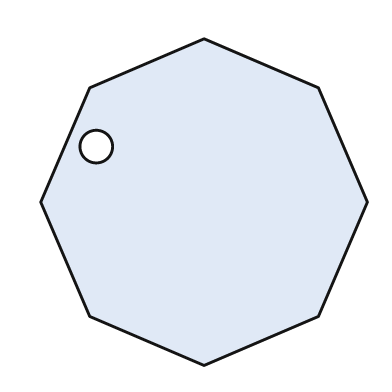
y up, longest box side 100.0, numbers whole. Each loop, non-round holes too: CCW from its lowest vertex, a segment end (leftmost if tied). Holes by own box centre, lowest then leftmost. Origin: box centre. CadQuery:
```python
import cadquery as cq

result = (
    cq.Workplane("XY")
    .moveTo(0.0, -50.0)
    .lineTo(35.0, -35.0)
    .lineTo(50.0, 0.0)
    .lineTo(35.0, 35.0)
    .lineTo(0.0, 50.0)
    .lineTo(-35.0, 35.0)
    .lineTo(-50.0, 0.0)
    .lineTo(-35.0, -35.0)
    .close()
    .moveTo(-33.0, 17.0)
    .circle(5.0)
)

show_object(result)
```